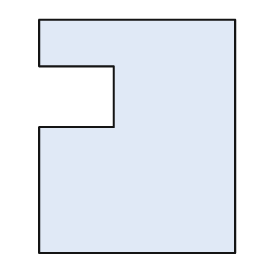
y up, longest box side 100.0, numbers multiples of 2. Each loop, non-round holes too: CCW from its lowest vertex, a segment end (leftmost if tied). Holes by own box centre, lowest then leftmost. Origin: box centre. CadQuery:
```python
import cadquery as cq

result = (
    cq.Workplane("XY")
    .moveTo(-42.0, -50.0)
    .lineTo(42.0, -50.0)
    .lineTo(42.0, 50.0)
    .lineTo(-42.0, 50.0)
    .lineTo(-42.0, 30.0)
    .lineTo(-10.0, 30.0)
    .lineTo(-10.0, 4.0)
    .lineTo(-42.0, 4.0)
    .close()
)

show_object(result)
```